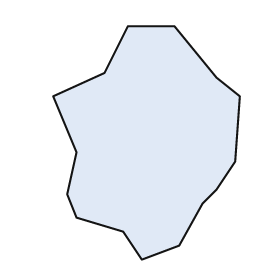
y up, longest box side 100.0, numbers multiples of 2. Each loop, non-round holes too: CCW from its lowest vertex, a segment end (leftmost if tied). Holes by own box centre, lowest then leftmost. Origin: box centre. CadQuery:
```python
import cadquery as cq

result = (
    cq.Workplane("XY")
    .moveTo(-2.0, -50.0)
    .lineTo(14.0, -44.0)
    .lineTo(24.0, -26.0)
    .lineTo(30.0, -20.0)
    .lineTo(38.0, -8.0)
    .lineTo(40.0, 20.0)
    .lineTo(30.0, 28.0)
    .lineTo(12.0, 50.0)
    .lineTo(-8.0, 50.0)
    .lineTo(-18.0, 30.0)
    .lineTo(-40.0, 20.0)
    .lineTo(-30.0, -4.0)
    .lineTo(-34.0, -22.0)
    .lineTo(-30.0, -32.0)
    .lineTo(-10.0, -38.0)
    .close()
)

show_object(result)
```